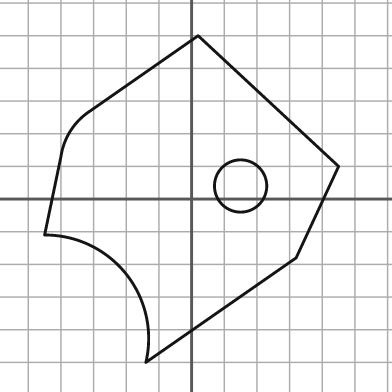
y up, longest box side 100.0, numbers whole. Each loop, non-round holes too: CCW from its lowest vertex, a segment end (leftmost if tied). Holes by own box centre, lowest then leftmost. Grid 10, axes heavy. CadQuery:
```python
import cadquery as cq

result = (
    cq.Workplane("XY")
    .moveTo(-14.0, -50.0)
    .lineTo(32.0, -18.0)
    .lineTo(45.0, 10.0)
    .lineTo(2.0, 50.0)
    .lineTo(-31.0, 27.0)
    .threePointArc((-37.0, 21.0), (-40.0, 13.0))
    .lineTo(-45.0, -11.0)
    .threePointArc((-20.0, -23.0), (-14.0, -50.0))
    .close()
    .moveTo(15.0, 4.0)
    .circle(8.0)
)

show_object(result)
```